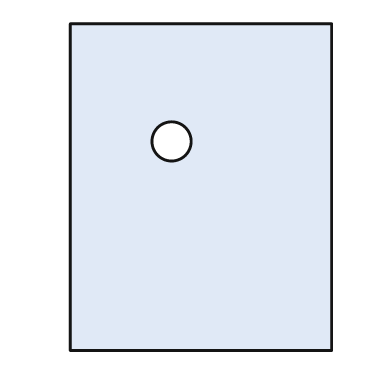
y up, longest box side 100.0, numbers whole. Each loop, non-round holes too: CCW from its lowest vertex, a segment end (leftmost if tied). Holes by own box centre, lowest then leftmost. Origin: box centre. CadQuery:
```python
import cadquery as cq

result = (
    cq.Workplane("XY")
    .moveTo(-40.0, -50.0)
    .lineTo(40.0, -50.0)
    .lineTo(40.0, 50.0)
    .lineTo(-40.0, 50.0)
    .close()
    .moveTo(-9.0, 14.0)
    .circle(6.0)
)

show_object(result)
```